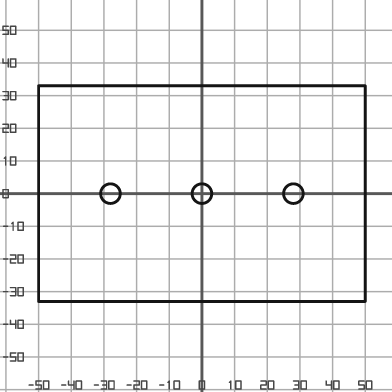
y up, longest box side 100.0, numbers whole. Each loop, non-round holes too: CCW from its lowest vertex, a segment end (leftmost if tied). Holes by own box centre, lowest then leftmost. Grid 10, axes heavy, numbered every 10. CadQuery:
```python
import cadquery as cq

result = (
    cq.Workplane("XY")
    .moveTo(-50.0, -33.0)
    .lineTo(50.0, -33.0)
    .lineTo(50.0, 33.0)
    .lineTo(-50.0, 33.0)
    .close()
    .moveTo(-28.0, 0.0)
    .circle(3.0)
    .moveTo(0.0, 0.0)
    .circle(3.0)
    .moveTo(28.0, 0.0)
    .circle(3.0)
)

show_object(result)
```